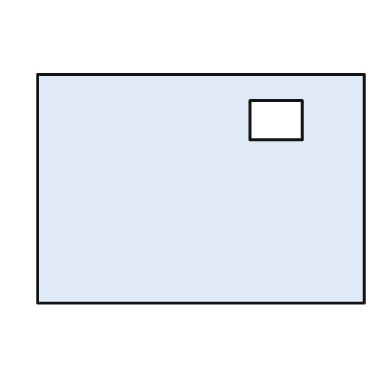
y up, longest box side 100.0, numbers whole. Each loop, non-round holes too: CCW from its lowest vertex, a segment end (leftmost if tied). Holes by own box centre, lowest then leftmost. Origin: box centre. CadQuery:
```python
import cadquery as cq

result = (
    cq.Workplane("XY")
    .moveTo(-50.0, -35.0)
    .lineTo(50.0, -35.0)
    .lineTo(50.0, 35.0)
    .lineTo(-50.0, 35.0)
    .close()
    .moveTo(15.0, 15.0)
    .lineTo(31.0, 15.0)
    .lineTo(31.0, 27.0)
    .lineTo(15.0, 27.0)
    .close()
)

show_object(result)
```